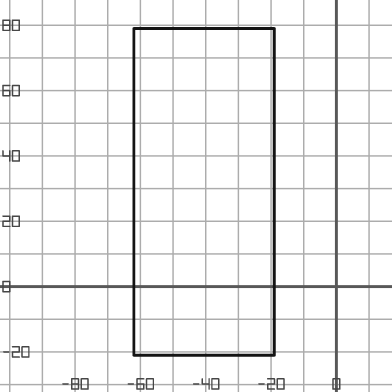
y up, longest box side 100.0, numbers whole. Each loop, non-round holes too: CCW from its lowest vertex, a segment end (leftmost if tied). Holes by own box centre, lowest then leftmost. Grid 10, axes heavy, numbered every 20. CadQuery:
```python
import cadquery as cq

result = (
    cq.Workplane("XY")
    .moveTo(-62.0, -21.0)
    .lineTo(-19.0, -21.0)
    .lineTo(-19.0, 79.0)
    .lineTo(-62.0, 79.0)
    .close()
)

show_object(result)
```